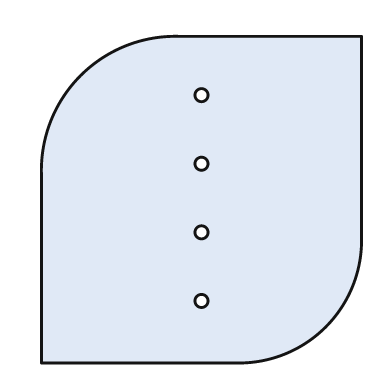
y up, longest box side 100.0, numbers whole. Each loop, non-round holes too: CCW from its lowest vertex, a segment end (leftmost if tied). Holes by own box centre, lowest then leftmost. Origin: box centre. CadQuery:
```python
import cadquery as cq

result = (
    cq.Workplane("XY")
    .moveTo(-49.0, -50.0)
    .lineTo(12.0, -50.0)
    .threePointArc((38.0, -39.0), (49.0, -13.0))
    .lineTo(49.0, 50.0)
    .lineTo(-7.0, 50.0)
    .threePointArc((-37.0, 38.0), (-49.0, 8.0))
    .close()
    .moveTo(0.0, -31.0)
    .circle(2.0)
    .moveTo(0.0, -10.0)
    .circle(2.0)
    .moveTo(0.0, 11.0)
    .circle(2.0)
    .moveTo(0.0, 32.0)
    .circle(2.0)
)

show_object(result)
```